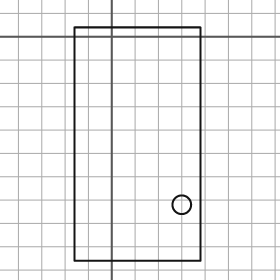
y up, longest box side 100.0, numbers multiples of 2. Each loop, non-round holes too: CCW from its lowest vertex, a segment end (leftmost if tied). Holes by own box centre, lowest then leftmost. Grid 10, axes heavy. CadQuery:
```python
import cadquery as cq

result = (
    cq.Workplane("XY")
    .moveTo(-16.0, -96.0)
    .lineTo(38.0, -96.0)
    .lineTo(38.0, 4.0)
    .lineTo(-16.0, 4.0)
    .close()
    .moveTo(30.0, -72.0)
    .circle(4.0)
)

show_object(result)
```